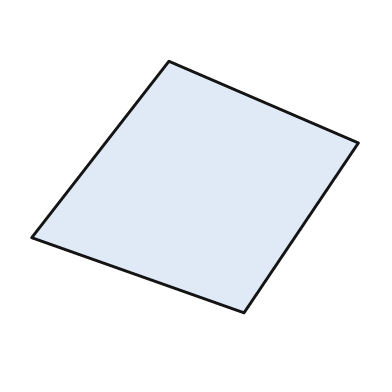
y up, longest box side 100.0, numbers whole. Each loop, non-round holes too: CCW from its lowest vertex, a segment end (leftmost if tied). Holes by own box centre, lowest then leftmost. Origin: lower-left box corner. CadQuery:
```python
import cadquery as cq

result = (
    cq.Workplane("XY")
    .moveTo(65.0, 0.0)
    .lineTo(100.0, 52.0)
    .lineTo(42.0, 77.0)
    .lineTo(0.0, 23.0)
    .close()
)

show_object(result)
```